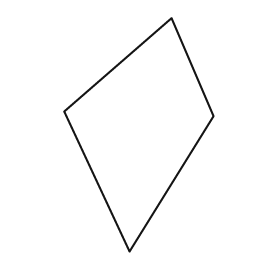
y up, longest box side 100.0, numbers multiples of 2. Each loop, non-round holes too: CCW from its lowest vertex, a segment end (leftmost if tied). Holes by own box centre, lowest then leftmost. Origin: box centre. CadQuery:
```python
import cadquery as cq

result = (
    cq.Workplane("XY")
    .moveTo(-4.0, -50.0)
    .lineTo(32.0, 8.0)
    .lineTo(14.0, 50.0)
    .lineTo(-32.0, 10.0)
    .close()
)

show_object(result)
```